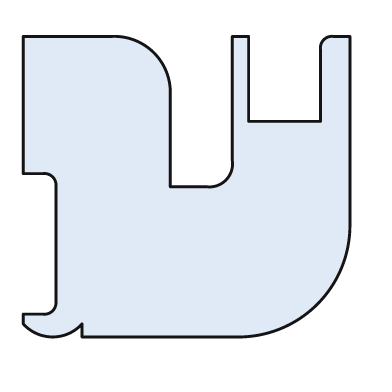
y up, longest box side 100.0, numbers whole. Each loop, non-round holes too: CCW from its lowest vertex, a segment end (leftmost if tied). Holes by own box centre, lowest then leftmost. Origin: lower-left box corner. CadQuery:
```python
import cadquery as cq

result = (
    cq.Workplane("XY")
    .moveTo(18.0, 0.0)
    .lineTo(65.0, 0.0)
    .threePointArc((90.0, 10.0), (100.0, 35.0))
    .lineTo(100.0, 92.0)
    .lineTo(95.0, 92.0)
    .threePointArc((92.0, 91.0), (91.0, 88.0))
    .lineTo(91.0, 66.0)
    .lineTo(69.0, 66.0)
    .lineTo(69.0, 92.0)
    .lineTo(64.0, 92.0)
    .lineTo(64.0, 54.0)
    .threePointArc((62.0, 48.0), (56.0, 46.0))
    .lineTo(45.0, 46.0)
    .lineTo(45.0, 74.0)
    .threePointArc((40.0, 87.0), (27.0, 92.0))
    .lineTo(0.0, 92.0)
    .lineTo(0.0, 50.0)
    .lineTo(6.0, 50.0)
    .threePointArc((9.0, 49.0), (10.0, 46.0))
    .lineTo(10.0, 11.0)
    .threePointArc((9.0, 8.0), (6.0, 7.0))
    .lineTo(0.0, 7.0)
    .lineTo(0.0, 4.0)
    .threePointArc((9.0, 0.0), (18.0, 4.0))
    .close()
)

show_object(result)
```